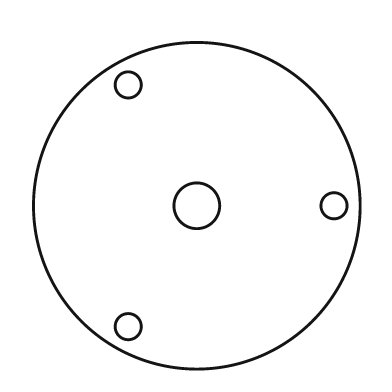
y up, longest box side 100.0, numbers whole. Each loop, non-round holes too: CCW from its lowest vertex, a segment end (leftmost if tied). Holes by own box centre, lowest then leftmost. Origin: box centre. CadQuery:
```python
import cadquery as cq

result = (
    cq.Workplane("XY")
    .moveTo(0.0, 0.0)
    .circle(50.0)
    .moveTo(-21.0, -37.0)
    .circle(4.0)
    .moveTo(0.0, 0.0)
    .circle(7.0)
    .moveTo(42.0, 0.0)
    .circle(4.0)
    .moveTo(-21.0, 37.0)
    .circle(4.0)
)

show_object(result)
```